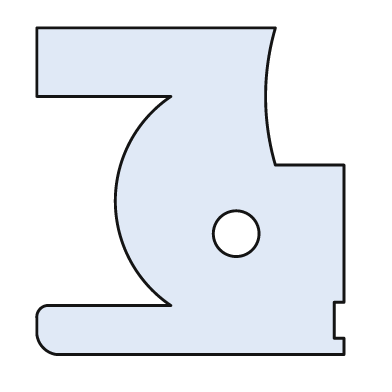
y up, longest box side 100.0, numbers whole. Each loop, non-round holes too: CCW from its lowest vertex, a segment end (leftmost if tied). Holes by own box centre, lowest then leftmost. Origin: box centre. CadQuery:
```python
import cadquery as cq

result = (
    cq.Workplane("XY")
    .moveTo(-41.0, -50.0)
    .lineTo(47.0, -50.0)
    .lineTo(47.0, -45.0)
    .lineTo(44.0, -45.0)
    .lineTo(44.0, -34.0)
    .lineTo(47.0, -34.0)
    .lineTo(47.0, 8.0)
    .lineTo(26.0, 8.0)
    .threePointArc((23.0, 29.0), (26.0, 50.0))
    .lineTo(-47.0, 50.0)
    .lineTo(-47.0, 29.0)
    .lineTo(-6.0, 29.0)
    .threePointArc((-23.0, -3.0), (-6.0, -35.0))
    .lineTo(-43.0, -35.0)
    .threePointArc((-46.0, -36.0), (-47.0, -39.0))
    .lineTo(-47.0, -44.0)
    .threePointArc((-45.0, -48.0), (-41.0, -50.0))
    .close()
    .moveTo(14.0, -13.0)
    .circle(7.0)
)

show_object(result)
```